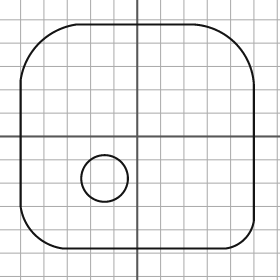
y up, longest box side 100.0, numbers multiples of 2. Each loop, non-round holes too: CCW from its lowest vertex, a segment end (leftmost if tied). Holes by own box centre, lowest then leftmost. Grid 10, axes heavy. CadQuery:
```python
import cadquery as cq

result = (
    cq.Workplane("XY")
    .moveTo(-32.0, -48.0)
    .lineTo(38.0, -48.0)
    .threePointArc((46.0, -44.0), (50.0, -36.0))
    .lineTo(50.0, 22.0)
    .threePointArc((42.0, 40.0), (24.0, 48.0))
    .lineTo(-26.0, 48.0)
    .threePointArc((-42.0, 40.0), (-50.0, 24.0))
    .lineTo(-50.0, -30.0)
    .threePointArc((-44.0, -42.0), (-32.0, -48.0))
    .close()
    .moveTo(-14.0, -18.0)
    .circle(10.0)
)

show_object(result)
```